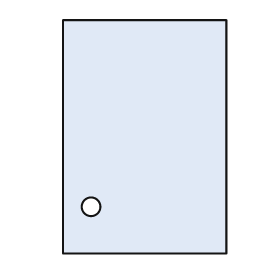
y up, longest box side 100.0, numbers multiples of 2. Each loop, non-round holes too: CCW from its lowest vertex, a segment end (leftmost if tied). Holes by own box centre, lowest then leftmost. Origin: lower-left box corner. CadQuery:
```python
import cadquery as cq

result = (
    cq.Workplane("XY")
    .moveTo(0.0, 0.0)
    .lineTo(70.0, 0.0)
    .lineTo(70.0, 100.0)
    .lineTo(0.0, 100.0)
    .close()
    .moveTo(12.0, 20.0)
    .circle(4.0)
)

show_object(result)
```